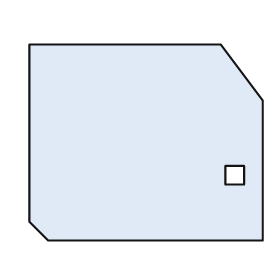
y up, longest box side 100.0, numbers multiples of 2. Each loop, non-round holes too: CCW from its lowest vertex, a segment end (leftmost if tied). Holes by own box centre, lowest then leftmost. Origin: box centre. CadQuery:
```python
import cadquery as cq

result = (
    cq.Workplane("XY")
    .moveTo(-42.0, -42.0)
    .lineTo(50.0, -42.0)
    .lineTo(50.0, 18.0)
    .lineTo(32.0, 42.0)
    .lineTo(-50.0, 42.0)
    .lineTo(-50.0, -34.0)
    .close()
    .moveTo(34.0, -18.0)
    .lineTo(42.0, -18.0)
    .lineTo(42.0, -10.0)
    .lineTo(34.0, -10.0)
    .close()
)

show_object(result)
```